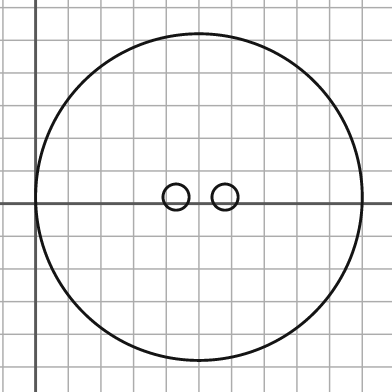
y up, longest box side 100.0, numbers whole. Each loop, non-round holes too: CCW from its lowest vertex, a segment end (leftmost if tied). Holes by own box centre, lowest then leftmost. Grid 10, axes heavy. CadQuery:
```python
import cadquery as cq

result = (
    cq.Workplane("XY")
    .moveTo(50.0, 2.0)
    .circle(50.0)
    .moveTo(43.0, 2.0)
    .circle(4.0)
    .moveTo(58.0, 2.0)
    .circle(4.0)
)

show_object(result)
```